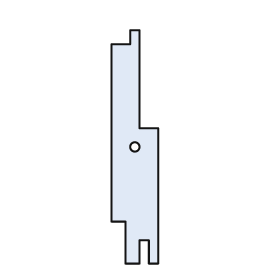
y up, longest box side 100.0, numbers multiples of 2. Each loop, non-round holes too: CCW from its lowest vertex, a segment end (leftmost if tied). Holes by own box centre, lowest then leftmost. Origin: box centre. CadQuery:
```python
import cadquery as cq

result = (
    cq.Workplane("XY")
    .moveTo(-4.0, -50.0)
    .lineTo(2.0, -50.0)
    .lineTo(2.0, -40.0)
    .lineTo(6.0, -40.0)
    .lineTo(6.0, -50.0)
    .lineTo(10.0, -50.0)
    .lineTo(10.0, 8.0)
    .lineTo(2.0, 8.0)
    .lineTo(2.0, 50.0)
    .lineTo(-2.0, 50.0)
    .lineTo(-2.0, 44.0)
    .lineTo(-10.0, 44.0)
    .lineTo(-10.0, -32.0)
    .lineTo(-4.0, -32.0)
    .close()
    .moveTo(0.0, 0.0)
    .circle(2.0)
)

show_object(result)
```